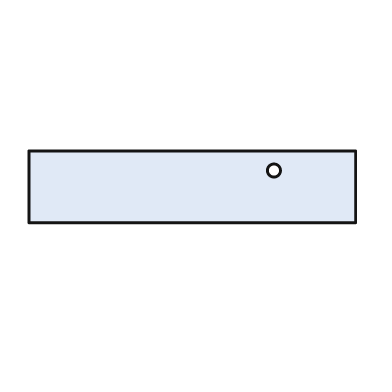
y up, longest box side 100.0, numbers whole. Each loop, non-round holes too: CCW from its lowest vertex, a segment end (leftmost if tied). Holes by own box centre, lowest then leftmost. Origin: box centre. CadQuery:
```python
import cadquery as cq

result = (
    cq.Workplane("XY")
    .moveTo(-50.0, -11.0)
    .lineTo(50.0, -11.0)
    .lineTo(50.0, 11.0)
    .lineTo(-50.0, 11.0)
    .close()
    .moveTo(25.0, 5.0)
    .circle(2.0)
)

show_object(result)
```